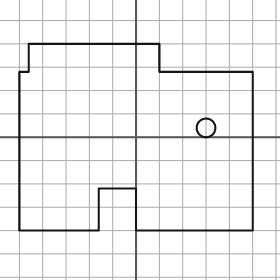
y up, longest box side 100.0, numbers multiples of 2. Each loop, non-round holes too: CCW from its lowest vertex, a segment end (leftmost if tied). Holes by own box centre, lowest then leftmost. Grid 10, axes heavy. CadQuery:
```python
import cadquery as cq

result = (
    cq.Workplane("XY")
    .moveTo(-50.0, -40.0)
    .lineTo(-16.0, -40.0)
    .lineTo(-16.0, -22.0)
    .lineTo(0.0, -22.0)
    .lineTo(0.0, -40.0)
    .lineTo(50.0, -40.0)
    .lineTo(50.0, 28.0)
    .lineTo(10.0, 28.0)
    .lineTo(10.0, 40.0)
    .lineTo(-46.0, 40.0)
    .lineTo(-46.0, 28.0)
    .lineTo(-50.0, 28.0)
    .close()
    .moveTo(30.0, 4.0)
    .circle(4.0)
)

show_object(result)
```